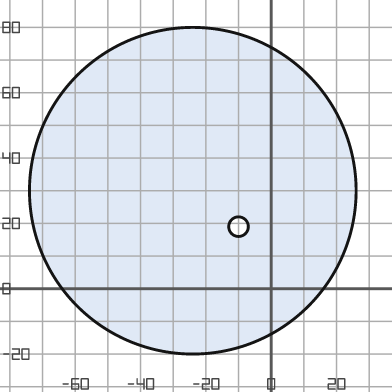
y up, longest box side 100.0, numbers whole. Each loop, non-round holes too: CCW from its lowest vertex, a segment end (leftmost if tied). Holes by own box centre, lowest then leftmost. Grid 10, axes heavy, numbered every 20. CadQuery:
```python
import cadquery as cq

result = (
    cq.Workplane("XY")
    .moveTo(-24.0, 30.0)
    .circle(50.0)
    .moveTo(-10.0, 19.0)
    .circle(3.0)
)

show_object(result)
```